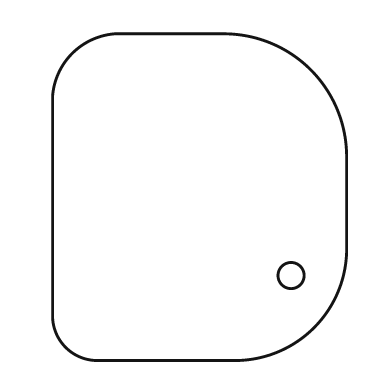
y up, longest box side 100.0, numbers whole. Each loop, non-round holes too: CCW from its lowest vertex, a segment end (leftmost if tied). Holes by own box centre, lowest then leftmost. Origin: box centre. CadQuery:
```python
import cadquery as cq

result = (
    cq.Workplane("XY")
    .moveTo(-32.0, -50.0)
    .lineTo(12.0, -50.0)
    .threePointArc((35.0, -40.0), (45.0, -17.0))
    .lineTo(45.0, 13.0)
    .threePointArc((34.0, 39.0), (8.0, 50.0))
    .lineTo(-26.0, 50.0)
    .threePointArc((-39.0, 44.0), (-45.0, 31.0))
    .lineTo(-45.0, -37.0)
    .threePointArc((-41.0, -46.0), (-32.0, -50.0))
    .close()
    .moveTo(28.0, -24.0)
    .circle(4.0)
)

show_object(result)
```